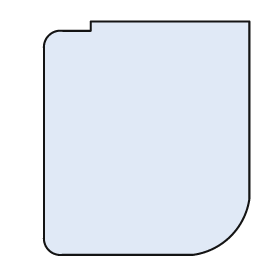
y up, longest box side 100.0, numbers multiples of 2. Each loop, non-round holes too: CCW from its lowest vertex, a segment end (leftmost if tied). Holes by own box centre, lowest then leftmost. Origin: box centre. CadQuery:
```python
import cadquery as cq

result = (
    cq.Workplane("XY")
    .moveTo(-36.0, -50.0)
    .lineTo(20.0, -50.0)
    .threePointArc((36.0, -42.0), (44.0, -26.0))
    .lineTo(44.0, 50.0)
    .lineTo(-24.0, 50.0)
    .lineTo(-24.0, 46.0)
    .lineTo(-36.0, 46.0)
    .threePointArc((-42.0, 44.0), (-44.0, 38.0))
    .lineTo(-44.0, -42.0)
    .threePointArc((-42.0, -48.0), (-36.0, -50.0))
    .close()
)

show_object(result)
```